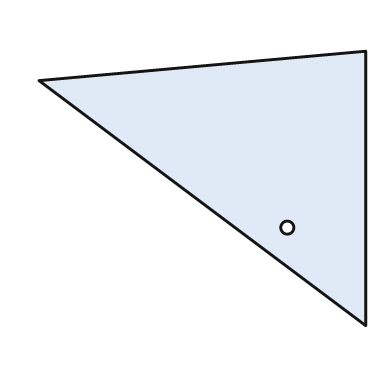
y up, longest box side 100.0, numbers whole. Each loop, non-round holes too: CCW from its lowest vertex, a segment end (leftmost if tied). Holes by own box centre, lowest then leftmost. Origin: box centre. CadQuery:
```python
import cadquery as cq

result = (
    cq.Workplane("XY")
    .moveTo(50.0, -42.0)
    .lineTo(50.0, 42.0)
    .lineTo(-50.0, 33.0)
    .close()
    .moveTo(26.0, -12.0)
    .circle(2.0)
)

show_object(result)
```